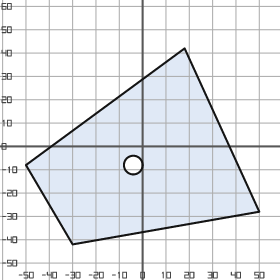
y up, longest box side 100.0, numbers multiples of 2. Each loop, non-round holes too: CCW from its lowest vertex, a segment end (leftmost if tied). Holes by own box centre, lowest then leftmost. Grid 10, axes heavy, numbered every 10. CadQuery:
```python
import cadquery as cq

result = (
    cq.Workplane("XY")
    .moveTo(-30.0, -42.0)
    .lineTo(50.0, -28.0)
    .lineTo(18.0, 42.0)
    .lineTo(-50.0, -8.0)
    .close()
    .moveTo(-4.0, -8.0)
    .circle(4.0)
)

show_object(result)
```